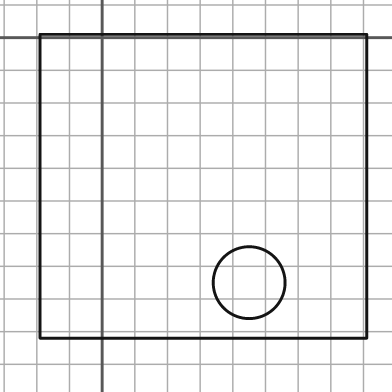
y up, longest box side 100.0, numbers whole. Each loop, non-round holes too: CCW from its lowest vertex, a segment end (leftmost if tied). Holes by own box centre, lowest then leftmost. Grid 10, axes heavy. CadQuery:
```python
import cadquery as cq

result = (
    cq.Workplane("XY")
    .moveTo(-19.0, -92.0)
    .lineTo(81.0, -92.0)
    .lineTo(81.0, 1.0)
    .lineTo(-19.0, 1.0)
    .close()
    .moveTo(45.0, -75.0)
    .circle(11.0)
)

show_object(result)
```